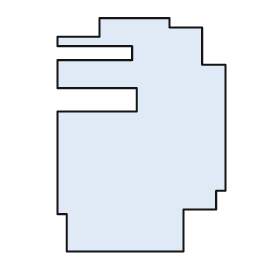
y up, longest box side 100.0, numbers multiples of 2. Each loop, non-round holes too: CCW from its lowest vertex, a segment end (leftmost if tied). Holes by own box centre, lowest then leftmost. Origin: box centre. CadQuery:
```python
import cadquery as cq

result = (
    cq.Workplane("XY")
    .moveTo(-32.0, -50.0)
    .lineTo(18.0, -50.0)
    .lineTo(18.0, -32.0)
    .lineTo(32.0, -32.0)
    .lineTo(32.0, -24.0)
    .lineTo(36.0, -24.0)
    .lineTo(36.0, 30.0)
    .lineTo(26.0, 30.0)
    .lineTo(26.0, 46.0)
    .lineTo(12.0, 46.0)
    .lineTo(12.0, 50.0)
    .lineTo(-18.0, 50.0)
    .lineTo(-18.0, 42.0)
    .lineTo(-36.0, 42.0)
    .lineTo(-36.0, 38.0)
    .lineTo(-4.0, 38.0)
    .lineTo(-4.0, 32.0)
    .lineTo(-36.0, 32.0)
    .lineTo(-36.0, 20.0)
    .lineTo(-2.0, 20.0)
    .lineTo(-2.0, 10.0)
    .lineTo(-36.0, 10.0)
    .lineTo(-36.0, -34.0)
    .lineTo(-32.0, -34.0)
    .close()
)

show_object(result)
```